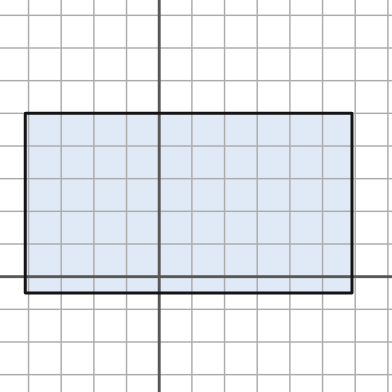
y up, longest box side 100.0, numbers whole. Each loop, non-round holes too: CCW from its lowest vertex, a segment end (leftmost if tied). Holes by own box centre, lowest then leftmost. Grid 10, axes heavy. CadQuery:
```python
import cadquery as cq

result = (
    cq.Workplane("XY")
    .moveTo(-41.0, -5.0)
    .lineTo(59.0, -5.0)
    .lineTo(59.0, 50.0)
    .lineTo(-41.0, 50.0)
    .close()
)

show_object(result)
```